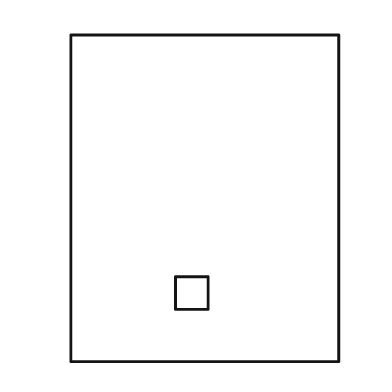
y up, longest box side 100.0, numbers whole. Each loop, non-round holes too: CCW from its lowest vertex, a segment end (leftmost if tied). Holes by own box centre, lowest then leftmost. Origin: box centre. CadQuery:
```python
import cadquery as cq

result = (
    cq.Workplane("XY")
    .moveTo(-41.0, -50.0)
    .lineTo(41.0, -50.0)
    .lineTo(41.0, 50.0)
    .lineTo(-41.0, 50.0)
    .close()
    .moveTo(-9.0, -34.0)
    .lineTo(1.0, -34.0)
    .lineTo(1.0, -24.0)
    .lineTo(-9.0, -24.0)
    .close()
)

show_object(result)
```